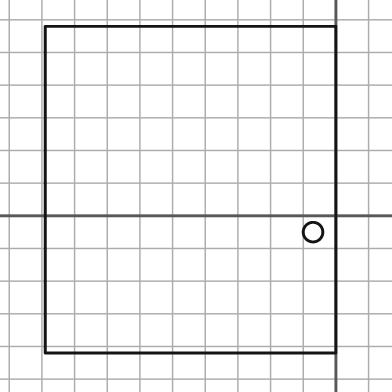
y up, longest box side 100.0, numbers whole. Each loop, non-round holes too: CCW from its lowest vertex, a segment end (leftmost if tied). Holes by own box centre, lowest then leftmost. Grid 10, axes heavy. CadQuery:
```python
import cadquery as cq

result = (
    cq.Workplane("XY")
    .moveTo(-89.0, -42.0)
    .lineTo(0.0, -42.0)
    .lineTo(0.0, 58.0)
    .lineTo(-89.0, 58.0)
    .close()
    .moveTo(-7.0, -5.0)
    .circle(3.0)
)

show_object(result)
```